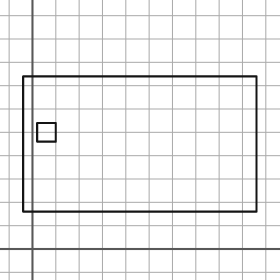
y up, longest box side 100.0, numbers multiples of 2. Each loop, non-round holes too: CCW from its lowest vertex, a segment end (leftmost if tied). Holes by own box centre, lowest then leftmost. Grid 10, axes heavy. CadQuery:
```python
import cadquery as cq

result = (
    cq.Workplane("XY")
    .moveTo(-4.0, 16.0)
    .lineTo(96.0, 16.0)
    .lineTo(96.0, 74.0)
    .lineTo(-4.0, 74.0)
    .close()
    .moveTo(2.0, 46.0)
    .lineTo(10.0, 46.0)
    .lineTo(10.0, 54.0)
    .lineTo(2.0, 54.0)
    .close()
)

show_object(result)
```